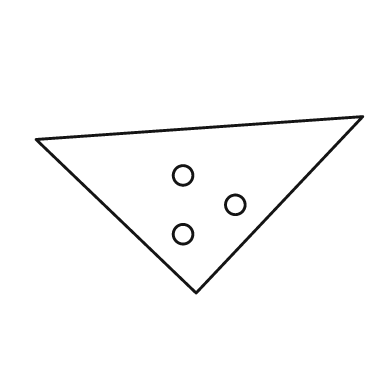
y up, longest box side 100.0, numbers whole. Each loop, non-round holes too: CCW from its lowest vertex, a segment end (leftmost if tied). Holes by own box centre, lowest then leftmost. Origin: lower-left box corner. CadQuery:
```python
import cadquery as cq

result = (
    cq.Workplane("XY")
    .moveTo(49.0, 0.0)
    .lineTo(100.0, 54.0)
    .lineTo(0.0, 47.0)
    .close()
    .moveTo(45.0, 18.0)
    .circle(3.0)
    .moveTo(61.0, 27.0)
    .circle(3.0)
    .moveTo(45.0, 36.0)
    .circle(3.0)
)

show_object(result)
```